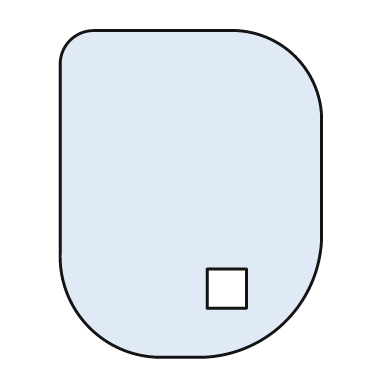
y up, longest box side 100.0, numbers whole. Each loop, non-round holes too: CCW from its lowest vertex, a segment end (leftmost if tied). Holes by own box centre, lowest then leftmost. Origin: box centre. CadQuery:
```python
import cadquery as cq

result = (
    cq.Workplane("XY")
    .moveTo(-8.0, -50.0)
    .lineTo(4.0, -50.0)
    .threePointArc((29.0, -39.0), (40.0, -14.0))
    .lineTo(40.0, 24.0)
    .threePointArc((32.0, 42.0), (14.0, 50.0))
    .lineTo(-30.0, 50.0)
    .threePointArc((-37.0, 47.0), (-40.0, 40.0))
    .lineTo(-40.0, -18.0)
    .threePointArc((-31.0, -41.0), (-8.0, -50.0))
    .close()
    .moveTo(5.0, -35.0)
    .lineTo(17.0, -35.0)
    .lineTo(17.0, -23.0)
    .lineTo(5.0, -23.0)
    .close()
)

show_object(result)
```